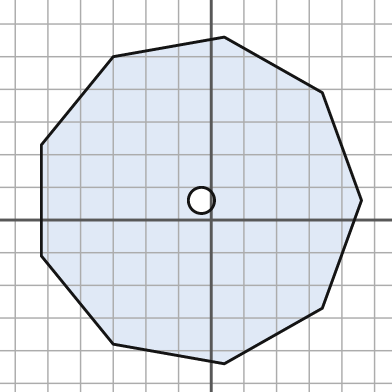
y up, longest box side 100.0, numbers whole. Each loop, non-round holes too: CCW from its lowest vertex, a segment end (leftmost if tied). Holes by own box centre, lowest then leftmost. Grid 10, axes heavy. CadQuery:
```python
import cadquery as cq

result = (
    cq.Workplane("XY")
    .moveTo(4.0, -44.0)
    .lineTo(34.0, -27.0)
    .lineTo(46.0, 6.0)
    .lineTo(34.0, 39.0)
    .lineTo(4.0, 56.0)
    .lineTo(-30.0, 50.0)
    .lineTo(-52.0, 23.0)
    .lineTo(-52.0, -11.0)
    .lineTo(-30.0, -38.0)
    .close()
    .moveTo(-3.0, 6.0)
    .circle(4.0)
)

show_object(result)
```